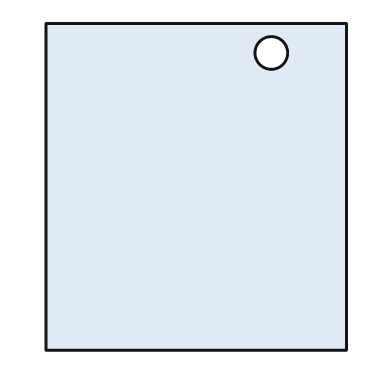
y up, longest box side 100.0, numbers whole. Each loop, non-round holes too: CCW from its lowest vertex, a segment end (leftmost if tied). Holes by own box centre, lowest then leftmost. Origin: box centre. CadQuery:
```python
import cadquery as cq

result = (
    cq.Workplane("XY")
    .moveTo(-46.0, -50.0)
    .lineTo(46.0, -50.0)
    .lineTo(46.0, 50.0)
    .lineTo(-46.0, 50.0)
    .close()
    .moveTo(23.0, 41.0)
    .circle(5.0)
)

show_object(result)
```